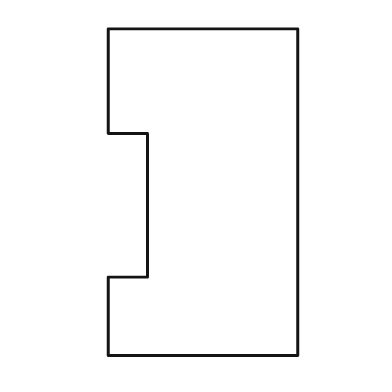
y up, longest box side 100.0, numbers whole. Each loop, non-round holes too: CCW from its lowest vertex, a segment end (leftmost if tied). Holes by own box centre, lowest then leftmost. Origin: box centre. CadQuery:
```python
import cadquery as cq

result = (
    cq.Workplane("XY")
    .moveTo(-29.0, -50.0)
    .lineTo(29.0, -50.0)
    .lineTo(29.0, 50.0)
    .lineTo(-29.0, 50.0)
    .lineTo(-29.0, 18.0)
    .lineTo(-17.0, 18.0)
    .lineTo(-17.0, -26.0)
    .lineTo(-29.0, -26.0)
    .close()
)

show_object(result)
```